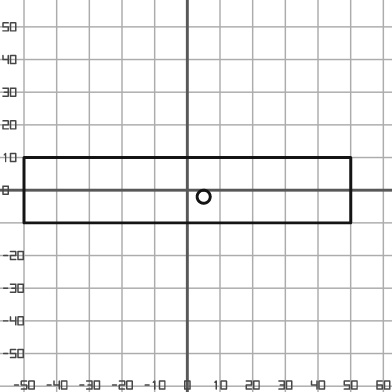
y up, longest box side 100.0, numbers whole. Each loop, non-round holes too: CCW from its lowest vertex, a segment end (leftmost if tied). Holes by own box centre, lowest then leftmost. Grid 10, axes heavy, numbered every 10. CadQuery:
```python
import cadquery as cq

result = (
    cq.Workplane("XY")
    .moveTo(-50.0, -10.0)
    .lineTo(50.0, -10.0)
    .lineTo(50.0, 10.0)
    .lineTo(-50.0, 10.0)
    .close()
    .moveTo(5.0, -2.0)
    .circle(2.0)
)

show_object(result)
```